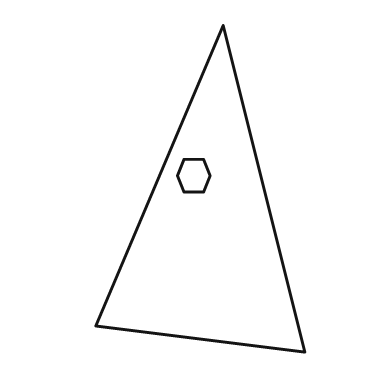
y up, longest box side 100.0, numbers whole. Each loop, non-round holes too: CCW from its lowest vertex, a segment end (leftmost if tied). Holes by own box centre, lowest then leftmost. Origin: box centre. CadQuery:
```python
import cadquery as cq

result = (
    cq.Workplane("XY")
    .moveTo(32.0, -50.0)
    .lineTo(7.0, 50.0)
    .lineTo(-32.0, -42.0)
    .close()
    .moveTo(-5.0, -1.0)
    .lineTo(1.0, -1.0)
    .lineTo(3.0, 4.0)
    .lineTo(1.0, 9.0)
    .lineTo(-5.0, 9.0)
    .lineTo(-7.0, 4.0)
    .close()
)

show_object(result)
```